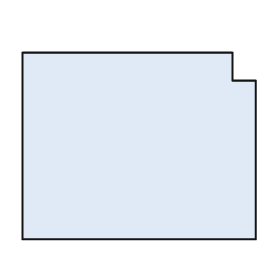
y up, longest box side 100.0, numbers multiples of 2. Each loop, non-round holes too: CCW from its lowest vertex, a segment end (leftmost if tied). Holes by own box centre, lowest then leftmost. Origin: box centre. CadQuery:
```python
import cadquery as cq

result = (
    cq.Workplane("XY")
    .moveTo(-50.0, -40.0)
    .lineTo(50.0, -40.0)
    .lineTo(50.0, 28.0)
    .lineTo(40.0, 28.0)
    .lineTo(40.0, 40.0)
    .lineTo(-50.0, 40.0)
    .close()
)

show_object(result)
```